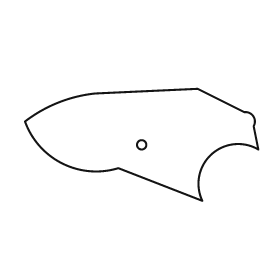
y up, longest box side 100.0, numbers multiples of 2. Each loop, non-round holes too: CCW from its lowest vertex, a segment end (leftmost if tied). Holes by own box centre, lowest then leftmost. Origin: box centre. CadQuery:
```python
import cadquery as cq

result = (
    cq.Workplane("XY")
    .moveTo(26.0, -24.0)
    .threePointArc((30.0, -4.0), (50.0, -2.0))
    .lineTo(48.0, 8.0)
    .threePointArc((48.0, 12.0), (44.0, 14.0))
    .lineTo(24.0, 24.0)
    .lineTo(-20.0, 22.0)
    .threePointArc((-36.0, 18.0), (-50.0, 10.0))
    .threePointArc((-34.0, -8.0), (-10.0, -10.0))
    .close()
    .moveTo(0.0, 0.0)
    .circle(2.0)
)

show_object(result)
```